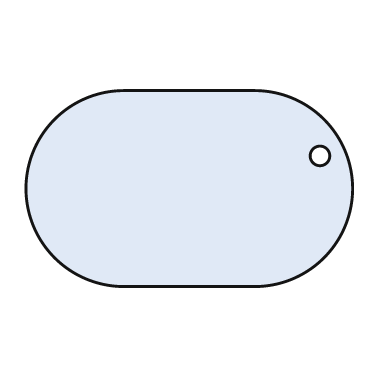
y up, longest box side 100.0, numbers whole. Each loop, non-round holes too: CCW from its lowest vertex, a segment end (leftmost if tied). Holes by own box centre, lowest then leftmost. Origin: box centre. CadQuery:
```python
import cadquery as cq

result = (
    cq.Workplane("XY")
    .moveTo(-20.0, -30.0)
    .lineTo(20.0, -30.0)
    .threePointArc((50.0, 0.0), (20.0, 30.0))
    .lineTo(-20.0, 30.0)
    .threePointArc((-50.0, 0.0), (-20.0, -30.0))
    .close()
    .moveTo(40.0, 10.0)
    .circle(3.0)
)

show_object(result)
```